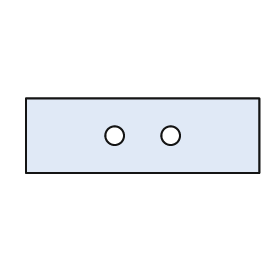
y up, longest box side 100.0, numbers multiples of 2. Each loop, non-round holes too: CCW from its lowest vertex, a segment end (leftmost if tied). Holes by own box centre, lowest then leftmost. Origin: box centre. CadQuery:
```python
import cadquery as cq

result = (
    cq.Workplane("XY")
    .moveTo(-50.0, -16.0)
    .lineTo(50.0, -16.0)
    .lineTo(50.0, 16.0)
    .lineTo(-50.0, 16.0)
    .close()
    .moveTo(-12.0, 0.0)
    .circle(4.0)
    .moveTo(12.0, 0.0)
    .circle(4.0)
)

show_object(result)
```